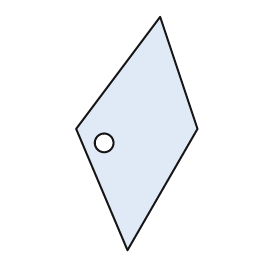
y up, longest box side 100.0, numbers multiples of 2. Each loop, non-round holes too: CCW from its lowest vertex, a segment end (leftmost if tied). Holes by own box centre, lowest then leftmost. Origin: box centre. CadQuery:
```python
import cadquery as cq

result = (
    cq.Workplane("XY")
    .moveTo(-4.0, -50.0)
    .lineTo(26.0, 2.0)
    .lineTo(10.0, 50.0)
    .lineTo(-26.0, 2.0)
    .close()
    .moveTo(-14.0, -4.0)
    .circle(4.0)
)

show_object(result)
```